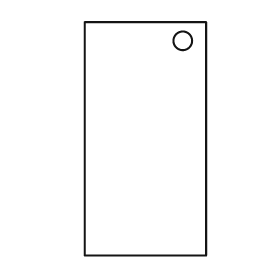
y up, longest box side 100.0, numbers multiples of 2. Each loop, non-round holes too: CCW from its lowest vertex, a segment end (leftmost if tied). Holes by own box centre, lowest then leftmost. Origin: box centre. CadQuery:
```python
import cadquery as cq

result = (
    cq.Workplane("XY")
    .moveTo(-26.0, -50.0)
    .lineTo(26.0, -50.0)
    .lineTo(26.0, 50.0)
    .lineTo(-26.0, 50.0)
    .close()
    .moveTo(16.0, 42.0)
    .circle(4.0)
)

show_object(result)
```